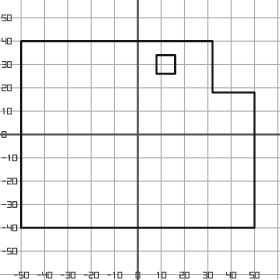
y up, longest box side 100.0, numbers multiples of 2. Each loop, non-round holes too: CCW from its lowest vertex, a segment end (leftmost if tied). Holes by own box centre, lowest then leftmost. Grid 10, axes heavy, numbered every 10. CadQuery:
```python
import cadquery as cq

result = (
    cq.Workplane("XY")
    .moveTo(-50.0, -40.0)
    .lineTo(50.0, -40.0)
    .lineTo(50.0, 18.0)
    .lineTo(32.0, 18.0)
    .lineTo(32.0, 40.0)
    .lineTo(-50.0, 40.0)
    .close()
    .moveTo(8.0, 26.0)
    .lineTo(16.0, 26.0)
    .lineTo(16.0, 34.0)
    .lineTo(8.0, 34.0)
    .close()
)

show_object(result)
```